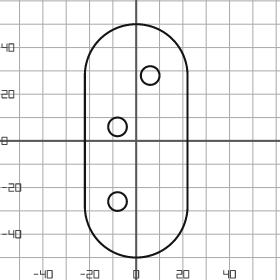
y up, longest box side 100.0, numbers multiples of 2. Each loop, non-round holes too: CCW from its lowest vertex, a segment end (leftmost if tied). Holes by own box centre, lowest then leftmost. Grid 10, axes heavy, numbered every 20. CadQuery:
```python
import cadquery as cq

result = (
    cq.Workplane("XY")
    .moveTo(-22.0, -28.0)
    .threePointArc((0.0, -50.0), (22.0, -28.0))
    .lineTo(22.0, 28.0)
    .threePointArc((0.0, 50.0), (-22.0, 28.0))
    .close()
    .moveTo(-8.0, -26.0)
    .circle(4.0)
    .moveTo(-8.0, 6.0)
    .circle(4.0)
    .moveTo(6.0, 28.0)
    .circle(4.0)
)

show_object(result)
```